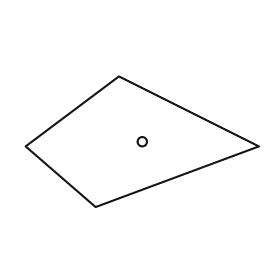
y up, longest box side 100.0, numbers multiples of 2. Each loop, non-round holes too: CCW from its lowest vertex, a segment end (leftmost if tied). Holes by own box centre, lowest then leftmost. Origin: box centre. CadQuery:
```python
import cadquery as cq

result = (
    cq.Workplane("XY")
    .moveTo(-20.0, -28.0)
    .lineTo(50.0, -2.0)
    .lineTo(-10.0, 28.0)
    .lineTo(-50.0, -2.0)
    .close()
    .moveTo(0.0, 0.0)
    .circle(2.0)
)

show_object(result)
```